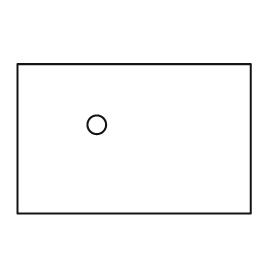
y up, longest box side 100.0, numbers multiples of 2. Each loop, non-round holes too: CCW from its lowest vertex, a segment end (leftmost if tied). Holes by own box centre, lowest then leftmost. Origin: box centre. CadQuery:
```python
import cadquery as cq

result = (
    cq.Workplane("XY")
    .moveTo(-50.0, -32.0)
    .lineTo(50.0, -32.0)
    .lineTo(50.0, 32.0)
    .lineTo(-50.0, 32.0)
    .close()
    .moveTo(-16.0, 6.0)
    .circle(4.0)
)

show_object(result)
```